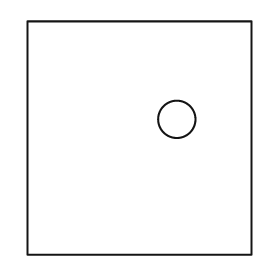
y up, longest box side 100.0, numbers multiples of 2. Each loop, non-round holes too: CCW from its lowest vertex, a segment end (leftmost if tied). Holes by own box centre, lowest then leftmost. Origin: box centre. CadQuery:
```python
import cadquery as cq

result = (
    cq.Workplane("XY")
    .moveTo(-48.0, -50.0)
    .lineTo(48.0, -50.0)
    .lineTo(48.0, 50.0)
    .lineTo(-48.0, 50.0)
    .close()
    .moveTo(16.0, 8.0)
    .circle(8.0)
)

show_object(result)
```